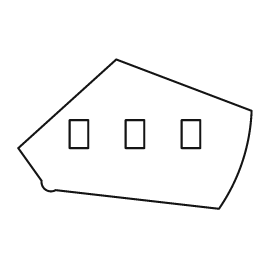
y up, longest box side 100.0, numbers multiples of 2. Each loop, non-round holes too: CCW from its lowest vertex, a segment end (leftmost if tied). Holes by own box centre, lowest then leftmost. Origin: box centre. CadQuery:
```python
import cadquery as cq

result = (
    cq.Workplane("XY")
    .moveTo(36.0, -32.0)
    .threePointArc((46.0, -12.0), (50.0, 10.0))
    .lineTo(-8.0, 32.0)
    .lineTo(-50.0, -6.0)
    .lineTo(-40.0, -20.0)
    .threePointArc((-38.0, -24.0), (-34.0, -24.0))
    .close()
    .moveTo(-28.0, -6.0)
    .lineTo(-20.0, -6.0)
    .lineTo(-20.0, 6.0)
    .lineTo(-28.0, 6.0)
    .close()
    .moveTo(-4.0, -6.0)
    .lineTo(4.0, -6.0)
    .lineTo(4.0, 6.0)
    .lineTo(-4.0, 6.0)
    .close()
    .moveTo(20.0, -6.0)
    .lineTo(28.0, -6.0)
    .lineTo(28.0, 6.0)
    .lineTo(20.0, 6.0)
    .close()
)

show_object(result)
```